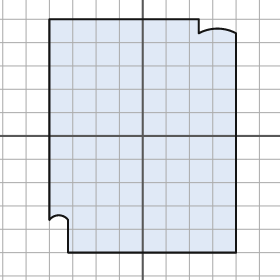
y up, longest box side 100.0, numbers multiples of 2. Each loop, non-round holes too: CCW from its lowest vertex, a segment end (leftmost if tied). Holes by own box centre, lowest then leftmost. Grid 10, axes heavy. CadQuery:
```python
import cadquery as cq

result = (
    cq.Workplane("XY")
    .moveTo(-32.0, -50.0)
    .lineTo(40.0, -50.0)
    .lineTo(40.0, 44.0)
    .threePointArc((32.0, 46.0), (24.0, 44.0))
    .lineTo(24.0, 50.0)
    .lineTo(-40.0, 50.0)
    .lineTo(-40.0, -36.0)
    .threePointArc((-36.0, -34.0), (-32.0, -36.0))
    .close()
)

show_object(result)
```